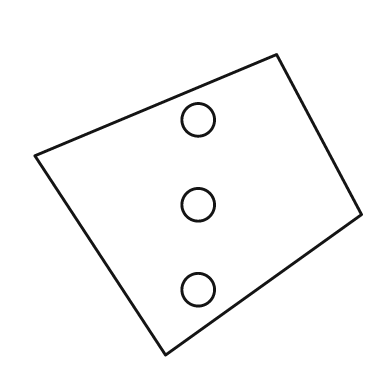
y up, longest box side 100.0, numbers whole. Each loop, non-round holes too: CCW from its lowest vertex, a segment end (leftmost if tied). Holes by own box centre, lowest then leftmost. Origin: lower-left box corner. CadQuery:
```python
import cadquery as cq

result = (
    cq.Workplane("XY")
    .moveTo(40.0, 0.0)
    .lineTo(100.0, 43.0)
    .lineTo(74.0, 92.0)
    .lineTo(0.0, 61.0)
    .close()
    .moveTo(50.0, 20.0)
    .circle(5.0)
    .moveTo(50.0, 46.0)
    .circle(5.0)
    .moveTo(50.0, 72.0)
    .circle(5.0)
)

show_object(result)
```